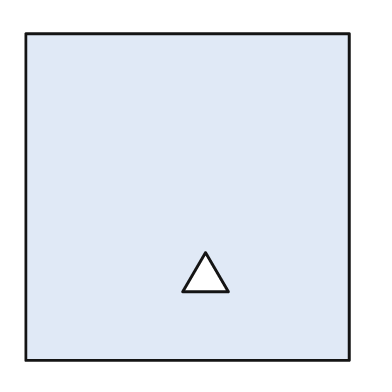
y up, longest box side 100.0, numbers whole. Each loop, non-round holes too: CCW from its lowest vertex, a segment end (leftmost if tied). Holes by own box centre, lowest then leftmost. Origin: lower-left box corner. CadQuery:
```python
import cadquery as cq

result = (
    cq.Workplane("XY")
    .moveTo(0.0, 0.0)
    .lineTo(99.0, 0.0)
    .lineTo(99.0, 100.0)
    .lineTo(0.0, 100.0)
    .close()
    .moveTo(48.0, 21.0)
    .lineTo(62.0, 21.0)
    .lineTo(55.0, 33.0)
    .close()
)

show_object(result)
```